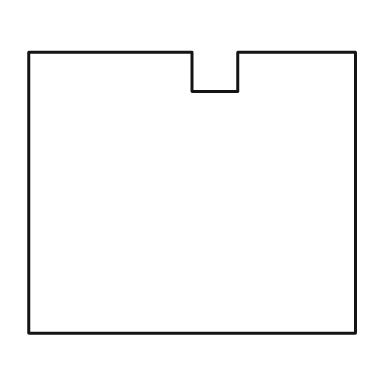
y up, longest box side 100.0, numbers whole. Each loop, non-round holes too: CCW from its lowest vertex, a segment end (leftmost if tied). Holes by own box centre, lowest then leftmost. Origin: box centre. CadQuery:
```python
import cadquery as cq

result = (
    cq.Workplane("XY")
    .moveTo(-50.0, -43.0)
    .lineTo(50.0, -43.0)
    .lineTo(50.0, 43.0)
    .lineTo(14.0, 43.0)
    .lineTo(14.0, 31.0)
    .lineTo(0.0, 31.0)
    .lineTo(0.0, 43.0)
    .lineTo(-50.0, 43.0)
    .close()
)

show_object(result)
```